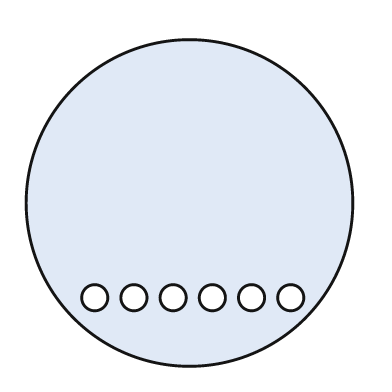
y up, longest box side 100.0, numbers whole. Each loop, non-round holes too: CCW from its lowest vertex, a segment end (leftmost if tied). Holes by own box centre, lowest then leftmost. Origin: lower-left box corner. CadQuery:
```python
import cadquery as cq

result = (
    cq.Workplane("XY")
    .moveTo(50.0, 50.0)
    .circle(50.0)
    .moveTo(21.0, 21.0)
    .circle(4.0)
    .moveTo(33.0, 21.0)
    .circle(4.0)
    .moveTo(45.0, 21.0)
    .circle(4.0)
    .moveTo(57.0, 21.0)
    .circle(4.0)
    .moveTo(69.0, 21.0)
    .circle(4.0)
    .moveTo(81.0, 21.0)
    .circle(4.0)
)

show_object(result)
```